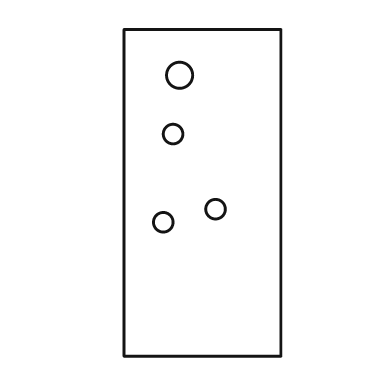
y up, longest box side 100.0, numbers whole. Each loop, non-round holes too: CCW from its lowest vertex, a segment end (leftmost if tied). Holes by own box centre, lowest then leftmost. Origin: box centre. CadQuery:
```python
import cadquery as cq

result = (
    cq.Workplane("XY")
    .moveTo(-24.0, -50.0)
    .lineTo(24.0, -50.0)
    .lineTo(24.0, 50.0)
    .lineTo(-24.0, 50.0)
    .close()
    .moveTo(-12.0, -9.0)
    .circle(3.0)
    .moveTo(4.0, -5.0)
    .circle(3.0)
    .moveTo(-9.0, 18.0)
    .circle(3.0)
    .moveTo(-7.0, 36.0)
    .circle(4.0)
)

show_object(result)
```